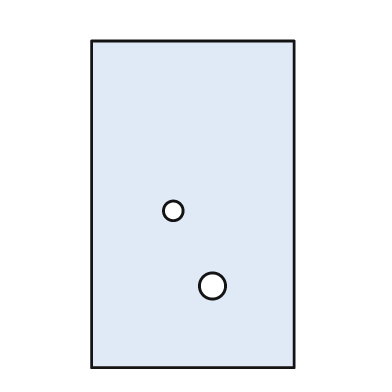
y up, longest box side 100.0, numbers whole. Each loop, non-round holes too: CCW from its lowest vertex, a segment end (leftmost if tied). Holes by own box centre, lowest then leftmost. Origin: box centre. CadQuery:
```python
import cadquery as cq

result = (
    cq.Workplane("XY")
    .moveTo(-31.0, -50.0)
    .lineTo(31.0, -50.0)
    .lineTo(31.0, 50.0)
    .lineTo(-31.0, 50.0)
    .close()
    .moveTo(6.0, -25.0)
    .circle(4.0)
    .moveTo(-6.0, -2.0)
    .circle(3.0)
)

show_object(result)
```